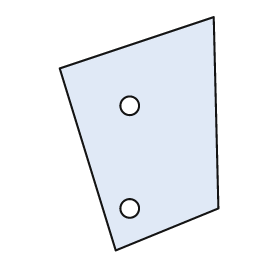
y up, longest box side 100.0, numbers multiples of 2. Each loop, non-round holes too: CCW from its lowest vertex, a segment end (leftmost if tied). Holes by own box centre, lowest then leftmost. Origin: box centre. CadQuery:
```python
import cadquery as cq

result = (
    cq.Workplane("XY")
    .moveTo(-10.0, -50.0)
    .lineTo(34.0, -32.0)
    .lineTo(32.0, 50.0)
    .lineTo(-34.0, 28.0)
    .close()
    .moveTo(-4.0, -32.0)
    .circle(4.0)
    .moveTo(-4.0, 12.0)
    .circle(4.0)
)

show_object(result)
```